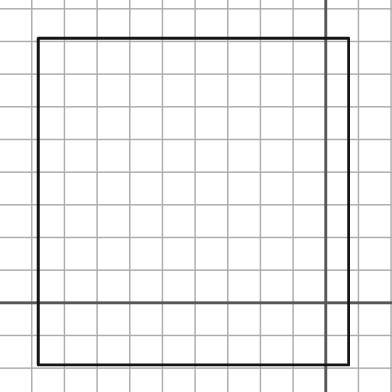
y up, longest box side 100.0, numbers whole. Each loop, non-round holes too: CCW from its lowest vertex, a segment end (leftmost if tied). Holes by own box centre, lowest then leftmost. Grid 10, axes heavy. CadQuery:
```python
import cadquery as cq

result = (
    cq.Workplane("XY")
    .moveTo(-88.0, -19.0)
    .lineTo(7.0, -19.0)
    .lineTo(7.0, 81.0)
    .lineTo(-88.0, 81.0)
    .close()
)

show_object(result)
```